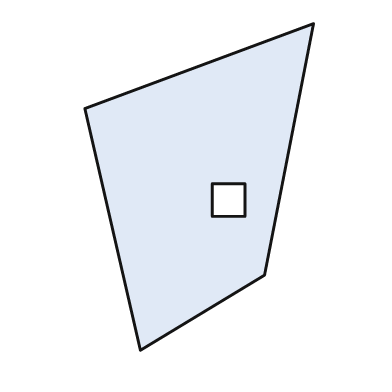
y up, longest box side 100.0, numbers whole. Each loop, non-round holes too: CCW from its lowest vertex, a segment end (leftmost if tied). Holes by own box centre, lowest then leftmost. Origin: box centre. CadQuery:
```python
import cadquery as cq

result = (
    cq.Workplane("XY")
    .moveTo(-18.0, -50.0)
    .lineTo(20.0, -27.0)
    .lineTo(35.0, 50.0)
    .lineTo(-35.0, 24.0)
    .close()
    .moveTo(4.0, -9.0)
    .lineTo(14.0, -9.0)
    .lineTo(14.0, 1.0)
    .lineTo(4.0, 1.0)
    .close()
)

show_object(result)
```